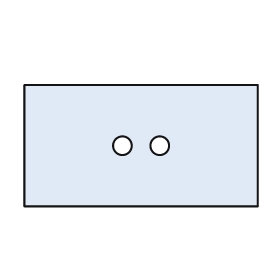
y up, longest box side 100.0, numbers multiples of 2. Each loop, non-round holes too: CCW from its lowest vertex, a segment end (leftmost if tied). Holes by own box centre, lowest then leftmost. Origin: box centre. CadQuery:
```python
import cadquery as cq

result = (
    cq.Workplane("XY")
    .moveTo(-50.0, -26.0)
    .lineTo(50.0, -26.0)
    .lineTo(50.0, 26.0)
    .lineTo(-50.0, 26.0)
    .close()
    .moveTo(-8.0, 0.0)
    .circle(4.0)
    .moveTo(8.0, 0.0)
    .circle(4.0)
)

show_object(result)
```